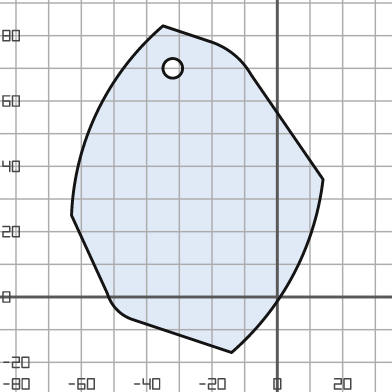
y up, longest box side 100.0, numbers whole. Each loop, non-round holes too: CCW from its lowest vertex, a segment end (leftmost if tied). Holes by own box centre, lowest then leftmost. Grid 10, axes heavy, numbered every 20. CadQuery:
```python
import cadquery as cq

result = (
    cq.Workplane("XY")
    .moveTo(-14.0, -17.0)
    .threePointArc((5.0, 7.0), (14.0, 36.0))
    .lineTo(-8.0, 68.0)
    .threePointArc((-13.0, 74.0), (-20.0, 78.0))
    .lineTo(-35.0, 83.0)
    .threePointArc((-55.0, 57.0), (-63.0, 25.0))
    .lineTo(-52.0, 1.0)
    .threePointArc((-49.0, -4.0), (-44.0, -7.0))
    .close()
    .moveTo(-32.0, 70.0)
    .circle(3.0)
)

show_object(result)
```